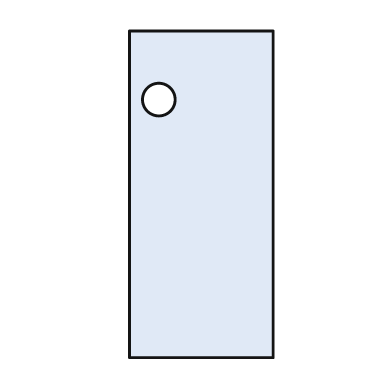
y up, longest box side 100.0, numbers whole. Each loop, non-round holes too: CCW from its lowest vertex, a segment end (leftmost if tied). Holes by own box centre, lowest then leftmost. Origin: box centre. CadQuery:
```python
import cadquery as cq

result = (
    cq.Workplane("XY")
    .moveTo(-22.0, -50.0)
    .lineTo(22.0, -50.0)
    .lineTo(22.0, 50.0)
    .lineTo(-22.0, 50.0)
    .close()
    .moveTo(-13.0, 29.0)
    .circle(5.0)
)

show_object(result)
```